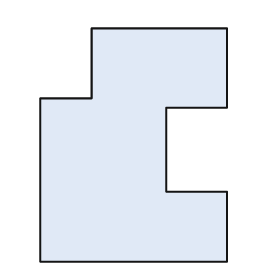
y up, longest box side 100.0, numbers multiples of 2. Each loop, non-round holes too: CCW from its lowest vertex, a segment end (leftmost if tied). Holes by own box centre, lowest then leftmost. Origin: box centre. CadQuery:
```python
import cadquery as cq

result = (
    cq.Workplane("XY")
    .moveTo(-40.0, -50.0)
    .lineTo(40.0, -50.0)
    .lineTo(40.0, -20.0)
    .lineTo(14.0, -20.0)
    .lineTo(14.0, 16.0)
    .lineTo(40.0, 16.0)
    .lineTo(40.0, 50.0)
    .lineTo(-18.0, 50.0)
    .lineTo(-18.0, 20.0)
    .lineTo(-40.0, 20.0)
    .close()
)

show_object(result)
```